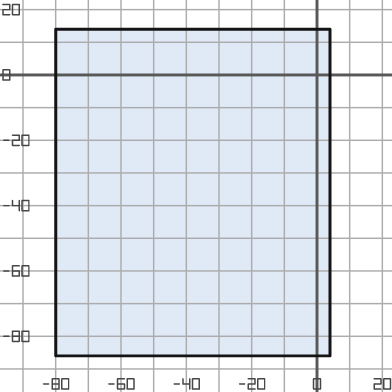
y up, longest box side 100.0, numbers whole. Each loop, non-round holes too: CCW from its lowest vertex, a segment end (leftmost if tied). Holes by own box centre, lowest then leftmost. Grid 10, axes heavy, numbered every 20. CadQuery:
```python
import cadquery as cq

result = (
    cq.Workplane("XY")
    .moveTo(-80.0, -86.0)
    .lineTo(4.0, -86.0)
    .lineTo(4.0, 14.0)
    .lineTo(-80.0, 14.0)
    .close()
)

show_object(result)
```